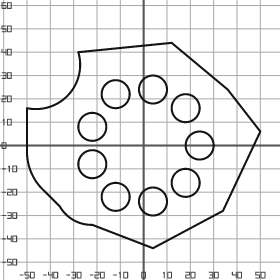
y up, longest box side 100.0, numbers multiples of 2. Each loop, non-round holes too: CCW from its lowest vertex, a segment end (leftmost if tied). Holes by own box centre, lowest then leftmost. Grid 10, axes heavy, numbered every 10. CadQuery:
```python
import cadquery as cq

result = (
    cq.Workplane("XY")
    .moveTo(4.0, -44.0)
    .lineTo(34.0, -28.0)
    .lineTo(50.0, 6.0)
    .lineTo(36.0, 24.0)
    .lineTo(12.0, 44.0)
    .lineTo(-28.0, 40.0)
    .threePointArc((-32.0, 22.0), (-50.0, 16.0))
    .lineTo(-50.0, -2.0)
    .threePointArc((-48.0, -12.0), (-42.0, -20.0))
    .lineTo(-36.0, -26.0)
    .threePointArc((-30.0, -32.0), (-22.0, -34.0))
    .close()
    .moveTo(4.0, -24.0)
    .circle(6.0)
    .moveTo(-12.0, -22.0)
    .circle(6.0)
    .moveTo(18.0, -16.0)
    .circle(6.0)
    .moveTo(-22.0, -8.0)
    .circle(6.0)
    .moveTo(24.0, 0.0)
    .circle(6.0)
    .moveTo(-22.0, 8.0)
    .circle(6.0)
    .moveTo(18.0, 16.0)
    .circle(6.0)
    .moveTo(-12.0, 22.0)
    .circle(6.0)
    .moveTo(4.0, 24.0)
    .circle(6.0)
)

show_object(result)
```